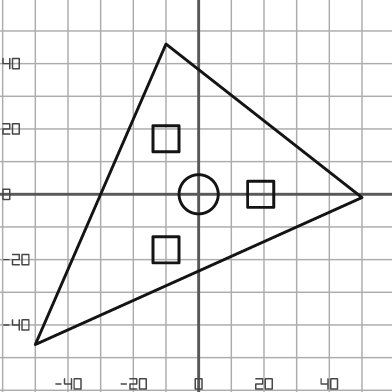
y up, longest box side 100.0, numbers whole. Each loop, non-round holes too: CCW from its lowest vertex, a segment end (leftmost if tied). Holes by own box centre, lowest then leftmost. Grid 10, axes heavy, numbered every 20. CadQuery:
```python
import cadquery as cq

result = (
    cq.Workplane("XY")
    .moveTo(-50.0, -46.0)
    .lineTo(50.0, -1.0)
    .lineTo(-10.0, 46.0)
    .close()
    .moveTo(-14.0, -21.0)
    .lineTo(-6.0, -21.0)
    .lineTo(-6.0, -13.0)
    .lineTo(-14.0, -13.0)
    .close()
    .moveTo(0.0, 0.0)
    .circle(6.0)
    .moveTo(15.0, -4.0)
    .lineTo(23.0, -4.0)
    .lineTo(23.0, 4.0)
    .lineTo(15.0, 4.0)
    .close()
    .moveTo(-14.0, 13.0)
    .lineTo(-6.0, 13.0)
    .lineTo(-6.0, 21.0)
    .lineTo(-14.0, 21.0)
    .close()
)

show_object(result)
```